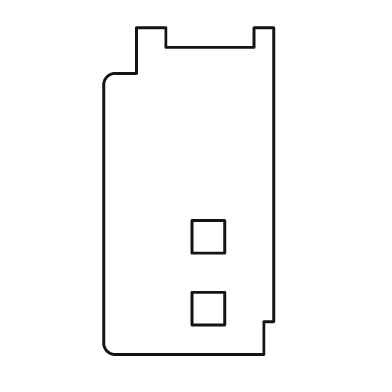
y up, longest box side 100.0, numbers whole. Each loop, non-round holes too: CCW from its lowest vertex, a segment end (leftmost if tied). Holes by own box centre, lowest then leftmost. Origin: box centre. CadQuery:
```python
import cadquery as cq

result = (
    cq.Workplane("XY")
    .moveTo(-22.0, -50.0)
    .lineTo(23.0, -50.0)
    .lineTo(23.0, -40.0)
    .lineTo(26.0, -40.0)
    .lineTo(26.0, 50.0)
    .lineTo(20.0, 50.0)
    .lineTo(20.0, 44.0)
    .lineTo(-7.0, 44.0)
    .lineTo(-7.0, 50.0)
    .lineTo(-16.0, 50.0)
    .lineTo(-16.0, 36.0)
    .lineTo(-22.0, 36.0)
    .threePointArc((-25.0, 35.0), (-26.0, 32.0))
    .lineTo(-26.0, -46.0)
    .threePointArc((-25.0, -49.0), (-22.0, -50.0))
    .close()
    .moveTo(1.0, -41.0)
    .lineTo(11.0, -41.0)
    .lineTo(11.0, -31.0)
    .lineTo(1.0, -31.0)
    .close()
    .moveTo(1.0, -19.0)
    .lineTo(11.0, -19.0)
    .lineTo(11.0, -9.0)
    .lineTo(1.0, -9.0)
    .close()
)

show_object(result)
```